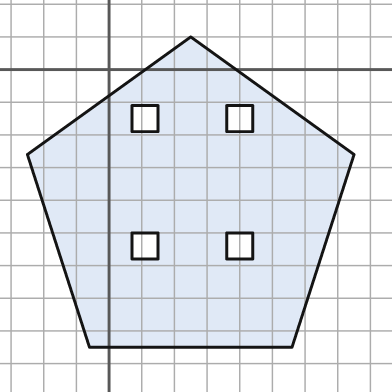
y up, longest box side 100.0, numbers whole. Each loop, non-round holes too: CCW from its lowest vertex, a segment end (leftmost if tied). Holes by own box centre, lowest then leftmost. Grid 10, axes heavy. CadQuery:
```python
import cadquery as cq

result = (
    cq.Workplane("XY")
    .moveTo(-6.0, -85.0)
    .lineTo(56.0, -85.0)
    .lineTo(75.0, -26.0)
    .lineTo(25.0, 10.0)
    .lineTo(-25.0, -26.0)
    .close()
    .moveTo(7.0, -58.0)
    .lineTo(15.0, -58.0)
    .lineTo(15.0, -50.0)
    .lineTo(7.0, -50.0)
    .close()
    .moveTo(36.0, -58.0)
    .lineTo(44.0, -58.0)
    .lineTo(44.0, -50.0)
    .lineTo(36.0, -50.0)
    .close()
    .moveTo(7.0, -19.0)
    .lineTo(15.0, -19.0)
    .lineTo(15.0, -11.0)
    .lineTo(7.0, -11.0)
    .close()
    .moveTo(36.0, -19.0)
    .lineTo(44.0, -19.0)
    .lineTo(44.0, -11.0)
    .lineTo(36.0, -11.0)
    .close()
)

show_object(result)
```